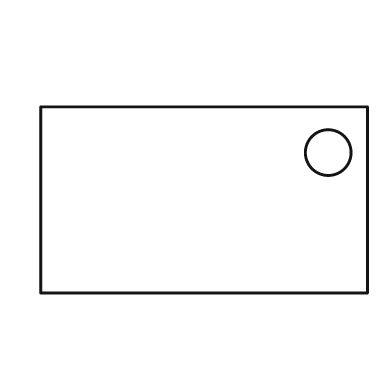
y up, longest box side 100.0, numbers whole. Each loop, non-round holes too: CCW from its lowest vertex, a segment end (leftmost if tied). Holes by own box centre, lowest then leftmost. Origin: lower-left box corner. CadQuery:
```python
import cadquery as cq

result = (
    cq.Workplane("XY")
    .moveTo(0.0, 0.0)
    .lineTo(100.0, 0.0)
    .lineTo(100.0, 57.0)
    .lineTo(0.0, 57.0)
    .close()
    .moveTo(88.0, 43.0)
    .circle(7.0)
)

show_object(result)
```